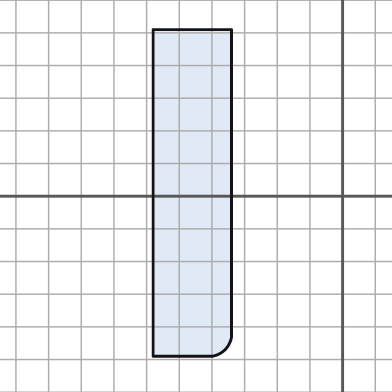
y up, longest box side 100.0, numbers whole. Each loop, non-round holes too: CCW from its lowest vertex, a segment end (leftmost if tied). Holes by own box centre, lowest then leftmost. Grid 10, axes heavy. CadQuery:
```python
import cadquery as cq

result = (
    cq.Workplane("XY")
    .moveTo(-58.0, -49.0)
    .lineTo(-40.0, -49.0)
    .threePointArc((-36.0, -47.0), (-34.0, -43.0))
    .lineTo(-34.0, 51.0)
    .lineTo(-58.0, 51.0)
    .close()
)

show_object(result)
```